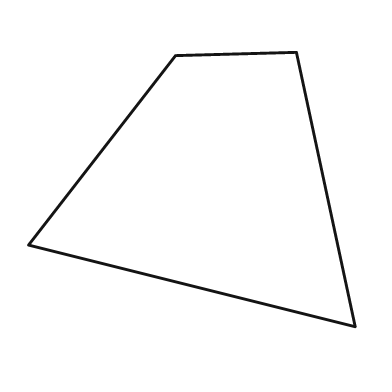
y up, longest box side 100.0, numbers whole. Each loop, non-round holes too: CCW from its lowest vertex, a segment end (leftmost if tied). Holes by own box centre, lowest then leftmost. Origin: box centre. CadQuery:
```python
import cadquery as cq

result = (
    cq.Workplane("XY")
    .moveTo(50.0, -42.0)
    .lineTo(32.0, 42.0)
    .lineTo(-5.0, 41.0)
    .lineTo(-50.0, -17.0)
    .close()
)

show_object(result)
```